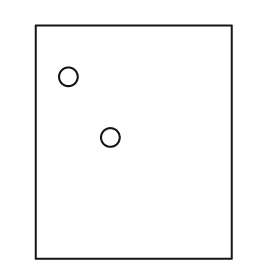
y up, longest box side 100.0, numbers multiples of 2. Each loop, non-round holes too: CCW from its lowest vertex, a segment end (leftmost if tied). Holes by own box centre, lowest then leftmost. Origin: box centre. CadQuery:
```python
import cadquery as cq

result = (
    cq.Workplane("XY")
    .moveTo(-42.0, -50.0)
    .lineTo(42.0, -50.0)
    .lineTo(42.0, 50.0)
    .lineTo(-42.0, 50.0)
    .close()
    .moveTo(-10.0, 2.0)
    .circle(4.0)
    .moveTo(-28.0, 28.0)
    .circle(4.0)
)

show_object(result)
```